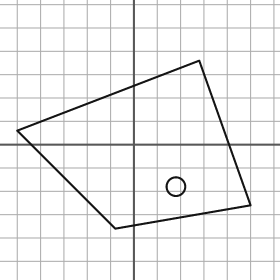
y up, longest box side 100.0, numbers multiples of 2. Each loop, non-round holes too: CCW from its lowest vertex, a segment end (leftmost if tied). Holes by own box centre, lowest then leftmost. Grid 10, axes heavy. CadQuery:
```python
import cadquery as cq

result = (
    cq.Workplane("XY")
    .moveTo(-8.0, -36.0)
    .lineTo(50.0, -26.0)
    .lineTo(28.0, 36.0)
    .lineTo(-50.0, 6.0)
    .close()
    .moveTo(18.0, -18.0)
    .circle(4.0)
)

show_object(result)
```